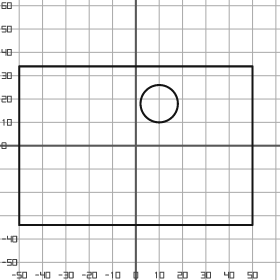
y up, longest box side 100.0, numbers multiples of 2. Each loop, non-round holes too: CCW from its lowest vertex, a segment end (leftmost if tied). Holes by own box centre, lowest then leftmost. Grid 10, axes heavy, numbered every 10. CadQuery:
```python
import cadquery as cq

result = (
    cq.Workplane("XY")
    .moveTo(-50.0, -34.0)
    .lineTo(50.0, -34.0)
    .lineTo(50.0, 34.0)
    .lineTo(-50.0, 34.0)
    .close()
    .moveTo(10.0, 18.0)
    .circle(8.0)
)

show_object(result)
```